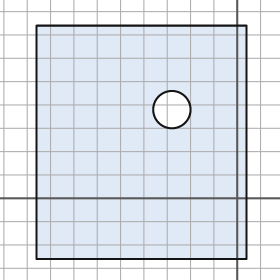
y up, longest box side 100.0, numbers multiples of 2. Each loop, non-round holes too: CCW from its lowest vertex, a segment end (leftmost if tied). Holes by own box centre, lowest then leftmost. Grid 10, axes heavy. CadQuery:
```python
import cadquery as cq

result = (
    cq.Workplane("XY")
    .moveTo(-86.0, -26.0)
    .lineTo(4.0, -26.0)
    .lineTo(4.0, 74.0)
    .lineTo(-86.0, 74.0)
    .close()
    .moveTo(-28.0, 38.0)
    .circle(8.0)
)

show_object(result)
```